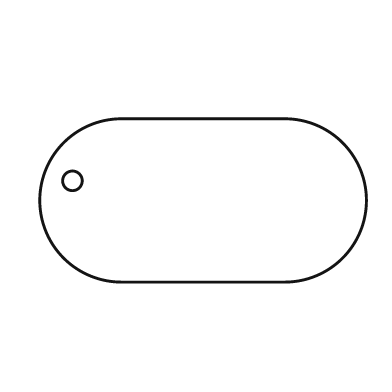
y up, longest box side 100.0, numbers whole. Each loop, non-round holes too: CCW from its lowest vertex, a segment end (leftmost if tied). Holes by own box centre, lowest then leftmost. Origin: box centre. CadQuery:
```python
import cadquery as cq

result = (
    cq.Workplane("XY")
    .moveTo(-25.0, -25.0)
    .lineTo(25.0, -25.0)
    .threePointArc((50.0, 0.0), (25.0, 25.0))
    .lineTo(-25.0, 25.0)
    .threePointArc((-50.0, 0.0), (-25.0, -25.0))
    .close()
    .moveTo(-40.0, 6.0)
    .circle(3.0)
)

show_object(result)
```